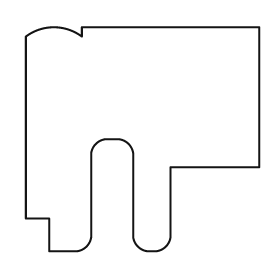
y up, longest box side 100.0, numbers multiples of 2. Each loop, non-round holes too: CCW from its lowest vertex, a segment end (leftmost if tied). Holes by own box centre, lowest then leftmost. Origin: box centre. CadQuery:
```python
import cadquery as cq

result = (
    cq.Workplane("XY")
    .moveTo(-40.0, -48.0)
    .lineTo(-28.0, -48.0)
    .threePointArc((-24.0, -46.0), (-22.0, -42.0))
    .lineTo(-22.0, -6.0)
    .threePointArc((-20.0, -2.0), (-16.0, 0.0))
    .lineTo(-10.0, 0.0)
    .threePointArc((-6.0, -2.0), (-4.0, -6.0))
    .lineTo(-4.0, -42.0)
    .threePointArc((-2.0, -46.0), (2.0, -48.0))
    .lineTo(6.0, -48.0)
    .threePointArc((10.0, -46.0), (12.0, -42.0))
    .lineTo(12.0, -12.0)
    .lineTo(50.0, -12.0)
    .lineTo(50.0, 48.0)
    .lineTo(-26.0, 48.0)
    .lineTo(-26.0, 44.0)
    .threePointArc((-38.0, 48.0), (-50.0, 44.0))
    .lineTo(-50.0, -34.0)
    .lineTo(-40.0, -34.0)
    .close()
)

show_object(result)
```